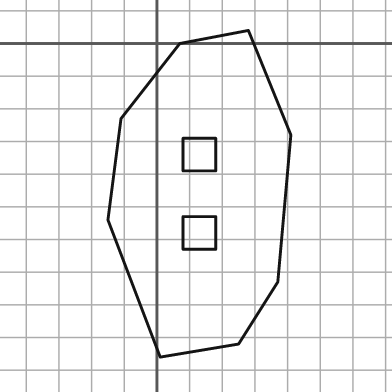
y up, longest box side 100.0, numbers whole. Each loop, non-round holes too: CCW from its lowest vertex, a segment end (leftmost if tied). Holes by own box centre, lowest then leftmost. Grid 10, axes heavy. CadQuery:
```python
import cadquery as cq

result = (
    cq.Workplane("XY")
    .moveTo(1.0, -96.0)
    .lineTo(25.0, -92.0)
    .lineTo(37.0, -73.0)
    .lineTo(41.0, -28.0)
    .lineTo(28.0, 4.0)
    .lineTo(7.0, 0.0)
    .lineTo(-11.0, -23.0)
    .lineTo(-15.0, -54.0)
    .close()
    .moveTo(8.0, -63.0)
    .lineTo(18.0, -63.0)
    .lineTo(18.0, -53.0)
    .lineTo(8.0, -53.0)
    .close()
    .moveTo(8.0, -39.0)
    .lineTo(18.0, -39.0)
    .lineTo(18.0, -29.0)
    .lineTo(8.0, -29.0)
    .close()
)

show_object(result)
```